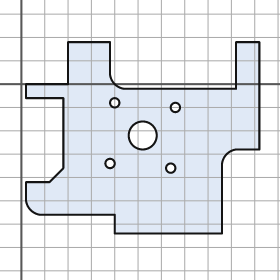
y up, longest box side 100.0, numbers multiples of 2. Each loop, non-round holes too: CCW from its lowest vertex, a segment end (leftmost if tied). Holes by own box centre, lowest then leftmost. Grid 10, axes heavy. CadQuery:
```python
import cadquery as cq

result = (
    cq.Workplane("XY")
    .moveTo(40.0, -64.0)
    .lineTo(86.0, -64.0)
    .lineTo(86.0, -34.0)
    .threePointArc((88.0, -30.0), (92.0, -28.0))
    .lineTo(102.0, -28.0)
    .lineTo(102.0, 18.0)
    .lineTo(92.0, 18.0)
    .lineTo(92.0, -2.0)
    .lineTo(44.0, -2.0)
    .threePointArc((40.0, 0.0), (38.0, 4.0))
    .lineTo(38.0, 18.0)
    .lineTo(20.0, 18.0)
    .lineTo(20.0, 0.0)
    .lineTo(2.0, 0.0)
    .lineTo(2.0, -6.0)
    .lineTo(18.0, -6.0)
    .lineTo(18.0, -36.0)
    .lineTo(12.0, -42.0)
    .lineTo(2.0, -42.0)
    .lineTo(2.0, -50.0)
    .threePointArc((4.0, -54.0), (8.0, -56.0))
    .lineTo(40.0, -56.0)
    .close()
    .moveTo(64.0, -36.0)
    .circle(2.0)
    .moveTo(38.0, -34.0)
    .circle(2.0)
    .moveTo(52.0, -22.0)
    .circle(6.0)
    .moveTo(66.0, -10.0)
    .circle(2.0)
    .moveTo(40.0, -8.0)
    .circle(2.0)
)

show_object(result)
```